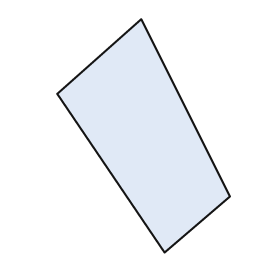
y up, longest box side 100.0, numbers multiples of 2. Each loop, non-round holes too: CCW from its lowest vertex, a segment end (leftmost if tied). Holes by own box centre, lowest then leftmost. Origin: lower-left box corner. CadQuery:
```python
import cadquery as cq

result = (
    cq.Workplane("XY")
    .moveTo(46.0, 0.0)
    .lineTo(74.0, 24.0)
    .lineTo(36.0, 100.0)
    .lineTo(0.0, 68.0)
    .close()
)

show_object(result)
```